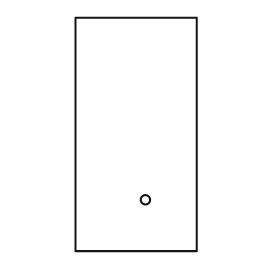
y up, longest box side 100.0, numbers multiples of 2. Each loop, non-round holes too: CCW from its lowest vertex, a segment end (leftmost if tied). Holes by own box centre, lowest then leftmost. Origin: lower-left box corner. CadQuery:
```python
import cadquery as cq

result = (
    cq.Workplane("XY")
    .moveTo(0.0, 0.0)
    .lineTo(52.0, 0.0)
    .lineTo(52.0, 100.0)
    .lineTo(0.0, 100.0)
    .close()
    .moveTo(30.0, 22.0)
    .circle(2.0)
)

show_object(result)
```